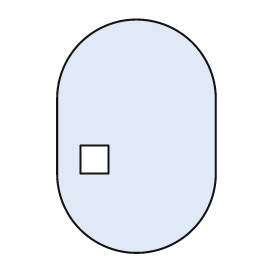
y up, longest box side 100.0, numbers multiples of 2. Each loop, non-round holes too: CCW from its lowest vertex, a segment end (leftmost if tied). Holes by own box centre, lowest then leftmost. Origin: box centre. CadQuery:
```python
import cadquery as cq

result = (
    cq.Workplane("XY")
    .moveTo(-34.0, -16.0)
    .threePointArc((0.0, -50.0), (34.0, -16.0))
    .lineTo(34.0, 16.0)
    .threePointArc((0.0, 50.0), (-34.0, 16.0))
    .close()
    .moveTo(-24.0, -16.0)
    .lineTo(-12.0, -16.0)
    .lineTo(-12.0, -4.0)
    .lineTo(-24.0, -4.0)
    .close()
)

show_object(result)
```